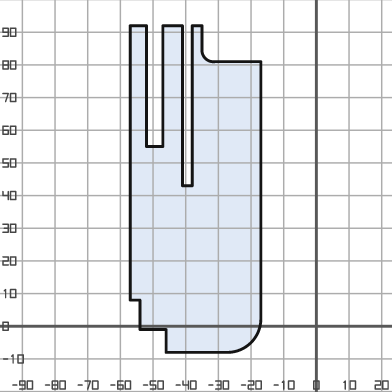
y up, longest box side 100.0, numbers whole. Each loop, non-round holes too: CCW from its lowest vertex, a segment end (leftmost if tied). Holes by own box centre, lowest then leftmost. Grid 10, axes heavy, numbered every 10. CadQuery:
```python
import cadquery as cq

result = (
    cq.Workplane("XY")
    .moveTo(-46.0, -8.0)
    .lineTo(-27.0, -8.0)
    .threePointArc((-20.0, -5.0), (-17.0, 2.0))
    .lineTo(-17.0, 81.0)
    .lineTo(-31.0, 81.0)
    .threePointArc((-34.0, 82.0), (-35.0, 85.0))
    .lineTo(-35.0, 92.0)
    .lineTo(-38.0, 92.0)
    .lineTo(-38.0, 43.0)
    .lineTo(-41.0, 43.0)
    .lineTo(-41.0, 92.0)
    .lineTo(-47.0, 92.0)
    .lineTo(-47.0, 55.0)
    .lineTo(-52.0, 55.0)
    .lineTo(-52.0, 92.0)
    .lineTo(-57.0, 92.0)
    .lineTo(-57.0, 8.0)
    .lineTo(-54.0, 8.0)
    .lineTo(-54.0, -1.0)
    .lineTo(-46.0, -1.0)
    .close()
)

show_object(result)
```